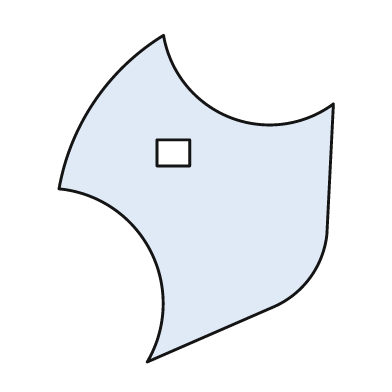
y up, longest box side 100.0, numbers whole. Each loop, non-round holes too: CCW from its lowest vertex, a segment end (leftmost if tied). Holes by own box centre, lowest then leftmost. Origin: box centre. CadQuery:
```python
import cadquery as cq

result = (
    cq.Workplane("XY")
    .moveTo(-15.0, -50.0)
    .lineTo(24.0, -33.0)
    .threePointArc((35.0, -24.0), (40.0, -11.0))
    .lineTo(42.0, 29.0)
    .threePointArc((10.0, 25.0), (-10.0, 50.0))
    .threePointArc((-31.0, 30.0), (-42.0, 3.0))
    .threePointArc((-14.0, -16.0), (-15.0, -50.0))
    .close()
    .moveTo(-12.0, 10.0)
    .lineTo(-2.0, 10.0)
    .lineTo(-2.0, 18.0)
    .lineTo(-12.0, 18.0)
    .close()
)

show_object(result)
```